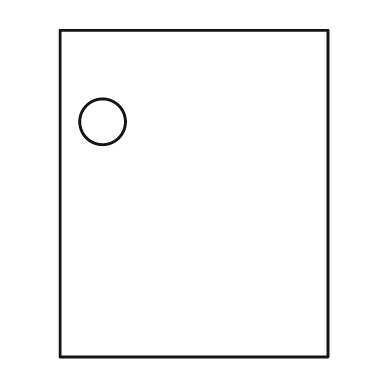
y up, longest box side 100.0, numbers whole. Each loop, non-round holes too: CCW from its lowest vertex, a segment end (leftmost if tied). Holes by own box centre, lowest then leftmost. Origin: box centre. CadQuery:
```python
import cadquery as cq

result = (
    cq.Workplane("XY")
    .moveTo(-41.0, -50.0)
    .lineTo(41.0, -50.0)
    .lineTo(41.0, 50.0)
    .lineTo(-41.0, 50.0)
    .close()
    .moveTo(-28.0, 22.0)
    .circle(7.0)
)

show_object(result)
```